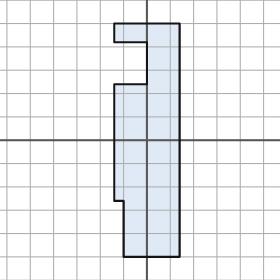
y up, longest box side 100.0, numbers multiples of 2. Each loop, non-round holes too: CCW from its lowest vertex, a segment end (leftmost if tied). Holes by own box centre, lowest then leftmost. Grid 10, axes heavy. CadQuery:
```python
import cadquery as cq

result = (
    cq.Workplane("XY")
    .moveTo(-10.0, -50.0)
    .lineTo(14.0, -50.0)
    .lineTo(14.0, 50.0)
    .lineTo(-14.0, 50.0)
    .lineTo(-14.0, 42.0)
    .lineTo(0.0, 42.0)
    .lineTo(0.0, 24.0)
    .lineTo(-14.0, 24.0)
    .lineTo(-14.0, -26.0)
    .lineTo(-10.0, -26.0)
    .close()
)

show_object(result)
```